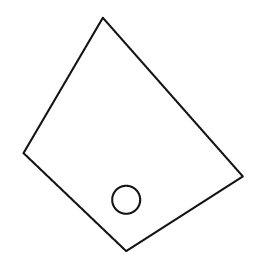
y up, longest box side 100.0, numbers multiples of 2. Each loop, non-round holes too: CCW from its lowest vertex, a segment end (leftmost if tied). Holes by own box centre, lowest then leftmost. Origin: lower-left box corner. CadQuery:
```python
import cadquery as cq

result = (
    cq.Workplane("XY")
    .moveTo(44.0, 0.0)
    .lineTo(94.0, 32.0)
    .lineTo(34.0, 100.0)
    .lineTo(0.0, 42.0)
    .close()
    .moveTo(44.0, 22.0)
    .circle(6.0)
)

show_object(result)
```